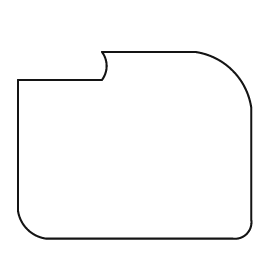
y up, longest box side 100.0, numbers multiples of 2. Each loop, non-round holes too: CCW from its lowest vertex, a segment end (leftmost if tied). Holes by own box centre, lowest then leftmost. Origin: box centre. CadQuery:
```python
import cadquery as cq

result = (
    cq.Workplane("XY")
    .moveTo(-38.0, -40.0)
    .lineTo(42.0, -40.0)
    .threePointArc((48.0, -38.0), (50.0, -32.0))
    .lineTo(50.0, 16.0)
    .threePointArc((42.0, 32.0), (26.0, 40.0))
    .lineTo(-14.0, 40.0)
    .threePointArc((-12.0, 34.0), (-14.0, 28.0))
    .lineTo(-50.0, 28.0)
    .lineTo(-50.0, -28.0)
    .threePointArc((-46.0, -36.0), (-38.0, -40.0))
    .close()
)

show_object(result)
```